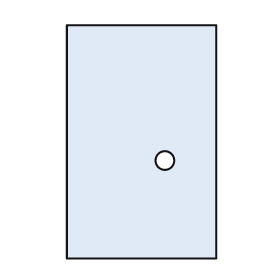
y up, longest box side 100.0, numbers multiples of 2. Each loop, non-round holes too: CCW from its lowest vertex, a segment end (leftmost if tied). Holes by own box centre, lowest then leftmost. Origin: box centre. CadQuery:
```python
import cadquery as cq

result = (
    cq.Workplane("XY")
    .moveTo(-32.0, -50.0)
    .lineTo(32.0, -50.0)
    .lineTo(32.0, 50.0)
    .lineTo(-32.0, 50.0)
    .close()
    .moveTo(10.0, -8.0)
    .circle(4.0)
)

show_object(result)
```